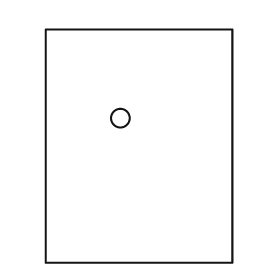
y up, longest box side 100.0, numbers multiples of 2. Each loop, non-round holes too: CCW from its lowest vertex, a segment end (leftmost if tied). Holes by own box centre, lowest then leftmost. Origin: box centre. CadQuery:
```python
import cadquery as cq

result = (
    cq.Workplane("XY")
    .moveTo(-40.0, -50.0)
    .lineTo(40.0, -50.0)
    .lineTo(40.0, 50.0)
    .lineTo(-40.0, 50.0)
    .close()
    .moveTo(-8.0, 12.0)
    .circle(4.0)
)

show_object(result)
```